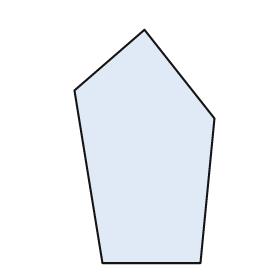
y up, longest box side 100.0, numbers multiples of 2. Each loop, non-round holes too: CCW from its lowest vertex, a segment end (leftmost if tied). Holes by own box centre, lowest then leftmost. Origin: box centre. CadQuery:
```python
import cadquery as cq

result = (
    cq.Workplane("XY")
    .moveTo(-18.0, -50.0)
    .lineTo(24.0, -50.0)
    .lineTo(30.0, 12.0)
    .lineTo(0.0, 50.0)
    .lineTo(-30.0, 24.0)
    .close()
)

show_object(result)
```